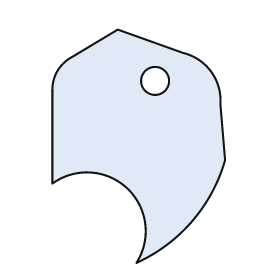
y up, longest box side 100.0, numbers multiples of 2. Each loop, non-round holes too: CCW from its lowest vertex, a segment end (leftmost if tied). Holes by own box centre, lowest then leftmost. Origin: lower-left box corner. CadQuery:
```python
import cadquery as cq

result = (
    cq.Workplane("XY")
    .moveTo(36.0, 0.0)
    .threePointArc((60.0, 18.0), (74.0, 44.0))
    .lineTo(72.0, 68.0)
    .threePointArc((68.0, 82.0), (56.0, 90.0))
    .lineTo(28.0, 100.0)
    .lineTo(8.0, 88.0)
    .threePointArc((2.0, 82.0), (0.0, 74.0))
    .lineTo(0.0, 34.0)
    .threePointArc((32.0, 32.0), (36.0, 0.0))
    .close()
    .moveTo(44.0, 78.0)
    .circle(6.0)
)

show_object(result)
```